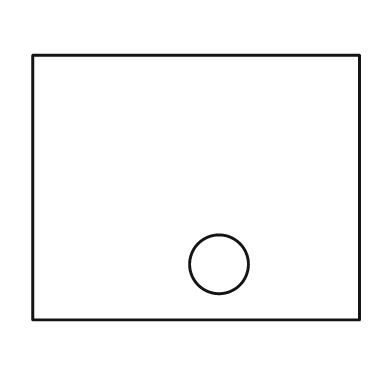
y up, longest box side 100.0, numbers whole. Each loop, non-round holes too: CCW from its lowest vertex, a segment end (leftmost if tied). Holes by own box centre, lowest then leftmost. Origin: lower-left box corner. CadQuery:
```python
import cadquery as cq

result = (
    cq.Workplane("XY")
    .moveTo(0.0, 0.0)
    .lineTo(100.0, 0.0)
    .lineTo(100.0, 81.0)
    .lineTo(0.0, 81.0)
    .close()
    .moveTo(57.0, 17.0)
    .circle(9.0)
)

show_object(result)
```